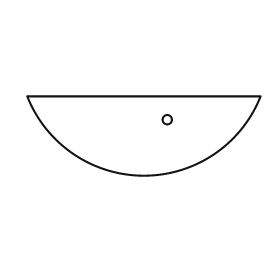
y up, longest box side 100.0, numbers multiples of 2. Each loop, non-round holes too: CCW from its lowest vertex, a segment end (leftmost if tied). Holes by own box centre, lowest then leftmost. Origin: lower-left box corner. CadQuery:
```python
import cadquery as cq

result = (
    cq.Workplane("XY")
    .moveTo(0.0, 34.0)
    .threePointArc((50.0, 0.0), (100.0, 34.0))
    .close()
    .moveTo(60.0, 24.0)
    .circle(2.0)
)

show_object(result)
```